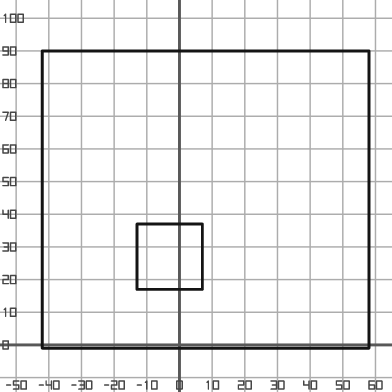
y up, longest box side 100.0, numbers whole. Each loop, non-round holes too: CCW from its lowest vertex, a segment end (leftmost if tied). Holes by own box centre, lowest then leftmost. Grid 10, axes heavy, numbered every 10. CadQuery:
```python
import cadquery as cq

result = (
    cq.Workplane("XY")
    .moveTo(-42.0, -1.0)
    .lineTo(58.0, -1.0)
    .lineTo(58.0, 90.0)
    .lineTo(-42.0, 90.0)
    .close()
    .moveTo(-13.0, 17.0)
    .lineTo(7.0, 17.0)
    .lineTo(7.0, 37.0)
    .lineTo(-13.0, 37.0)
    .close()
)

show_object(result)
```